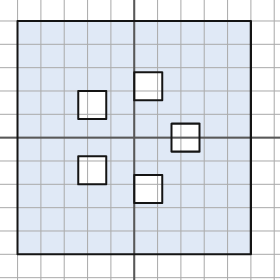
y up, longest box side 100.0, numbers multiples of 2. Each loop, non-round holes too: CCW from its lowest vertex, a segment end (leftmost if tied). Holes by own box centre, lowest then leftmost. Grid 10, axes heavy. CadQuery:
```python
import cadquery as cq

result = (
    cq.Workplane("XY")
    .moveTo(-50.0, -50.0)
    .lineTo(50.0, -50.0)
    .lineTo(50.0, 50.0)
    .lineTo(-50.0, 50.0)
    .close()
    .moveTo(0.0, -28.0)
    .lineTo(12.0, -28.0)
    .lineTo(12.0, -16.0)
    .lineTo(0.0, -16.0)
    .close()
    .moveTo(-24.0, -20.0)
    .lineTo(-12.0, -20.0)
    .lineTo(-12.0, -8.0)
    .lineTo(-24.0, -8.0)
    .close()
    .moveTo(16.0, -6.0)
    .lineTo(28.0, -6.0)
    .lineTo(28.0, 6.0)
    .lineTo(16.0, 6.0)
    .close()
    .moveTo(-24.0, 8.0)
    .lineTo(-12.0, 8.0)
    .lineTo(-12.0, 20.0)
    .lineTo(-24.0, 20.0)
    .close()
    .moveTo(0.0, 16.0)
    .lineTo(12.0, 16.0)
    .lineTo(12.0, 28.0)
    .lineTo(0.0, 28.0)
    .close()
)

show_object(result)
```